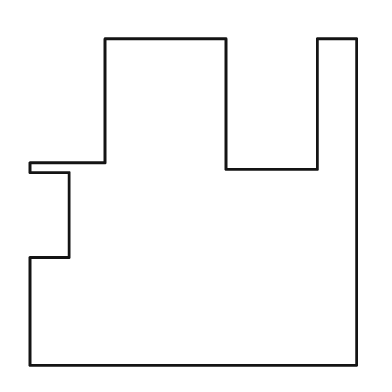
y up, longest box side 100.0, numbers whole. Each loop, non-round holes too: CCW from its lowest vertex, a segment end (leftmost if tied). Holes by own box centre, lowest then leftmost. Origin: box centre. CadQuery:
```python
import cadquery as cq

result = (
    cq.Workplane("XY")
    .moveTo(-50.0, -50.0)
    .lineTo(50.0, -50.0)
    .lineTo(50.0, 50.0)
    .lineTo(38.0, 50.0)
    .lineTo(38.0, 10.0)
    .lineTo(10.0, 10.0)
    .lineTo(10.0, 50.0)
    .lineTo(-27.0, 50.0)
    .lineTo(-27.0, 12.0)
    .lineTo(-50.0, 12.0)
    .lineTo(-50.0, 9.0)
    .lineTo(-38.0, 9.0)
    .lineTo(-38.0, -17.0)
    .lineTo(-50.0, -17.0)
    .close()
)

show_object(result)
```